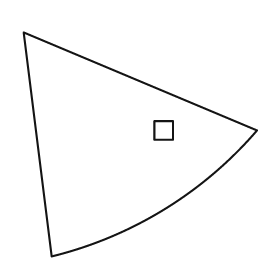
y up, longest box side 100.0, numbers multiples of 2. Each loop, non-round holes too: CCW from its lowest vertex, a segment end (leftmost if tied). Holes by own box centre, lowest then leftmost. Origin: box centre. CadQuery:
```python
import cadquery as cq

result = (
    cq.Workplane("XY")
    .moveTo(-38.0, -48.0)
    .threePointArc((10.0, -28.0), (50.0, 6.0))
    .lineTo(-50.0, 48.0)
    .close()
    .moveTo(6.0, 2.0)
    .lineTo(14.0, 2.0)
    .lineTo(14.0, 10.0)
    .lineTo(6.0, 10.0)
    .close()
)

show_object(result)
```